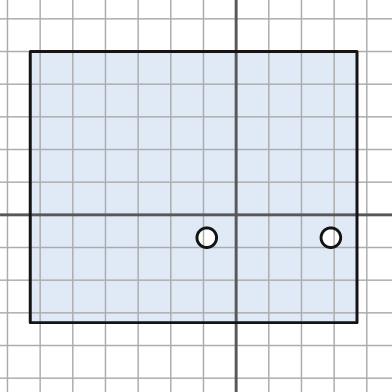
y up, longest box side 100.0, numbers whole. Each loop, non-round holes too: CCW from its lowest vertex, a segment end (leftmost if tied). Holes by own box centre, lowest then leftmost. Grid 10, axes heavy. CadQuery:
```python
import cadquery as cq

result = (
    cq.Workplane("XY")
    .moveTo(-63.0, -33.0)
    .lineTo(37.0, -33.0)
    .lineTo(37.0, 50.0)
    .lineTo(-63.0, 50.0)
    .close()
    .moveTo(-9.0, -7.0)
    .circle(3.0)
    .moveTo(29.0, -7.0)
    .circle(3.0)
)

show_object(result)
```